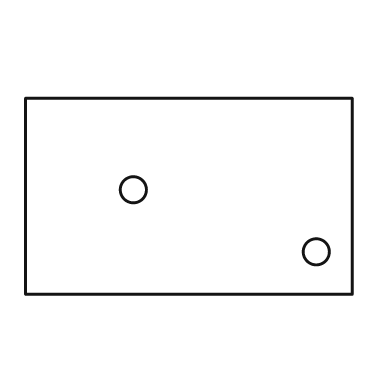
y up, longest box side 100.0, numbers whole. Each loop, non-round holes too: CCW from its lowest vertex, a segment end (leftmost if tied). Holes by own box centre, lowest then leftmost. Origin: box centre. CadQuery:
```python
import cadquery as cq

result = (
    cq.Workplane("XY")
    .moveTo(-50.0, -30.0)
    .lineTo(50.0, -30.0)
    .lineTo(50.0, 30.0)
    .lineTo(-50.0, 30.0)
    .close()
    .moveTo(39.0, -17.0)
    .circle(4.0)
    .moveTo(-17.0, 2.0)
    .circle(4.0)
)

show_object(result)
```